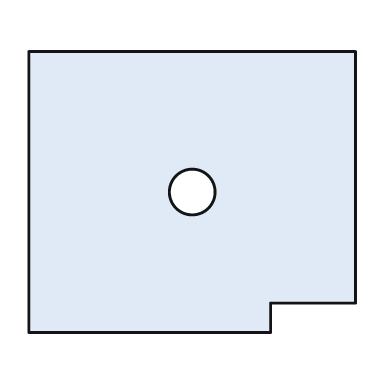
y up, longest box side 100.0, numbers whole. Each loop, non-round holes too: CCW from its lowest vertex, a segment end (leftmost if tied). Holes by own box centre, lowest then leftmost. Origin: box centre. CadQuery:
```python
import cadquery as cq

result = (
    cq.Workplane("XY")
    .moveTo(-50.0, -43.0)
    .lineTo(24.0, -43.0)
    .lineTo(24.0, -34.0)
    .lineTo(50.0, -34.0)
    .lineTo(50.0, 43.0)
    .lineTo(-50.0, 43.0)
    .close()
    .moveTo(0.0, 0.0)
    .circle(7.0)
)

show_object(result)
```